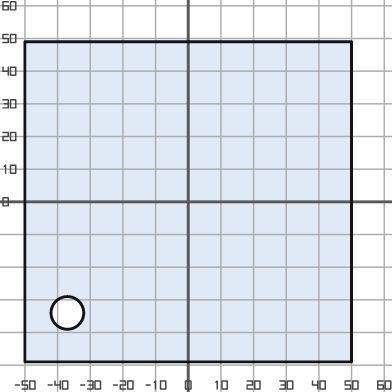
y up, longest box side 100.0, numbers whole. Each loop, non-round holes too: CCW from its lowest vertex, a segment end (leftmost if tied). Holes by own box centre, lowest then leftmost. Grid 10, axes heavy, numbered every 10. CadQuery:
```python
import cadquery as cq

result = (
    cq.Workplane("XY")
    .moveTo(-50.0, -49.0)
    .lineTo(50.0, -49.0)
    .lineTo(50.0, 49.0)
    .lineTo(-50.0, 49.0)
    .close()
    .moveTo(-37.0, -34.0)
    .circle(5.0)
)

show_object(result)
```